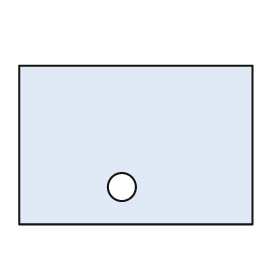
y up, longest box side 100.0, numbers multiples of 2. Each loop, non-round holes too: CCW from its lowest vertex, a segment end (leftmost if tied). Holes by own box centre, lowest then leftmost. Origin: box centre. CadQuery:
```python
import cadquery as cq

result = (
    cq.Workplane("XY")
    .moveTo(-50.0, -34.0)
    .lineTo(50.0, -34.0)
    .lineTo(50.0, 34.0)
    .lineTo(-50.0, 34.0)
    .close()
    .moveTo(-6.0, -18.0)
    .circle(6.0)
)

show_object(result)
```